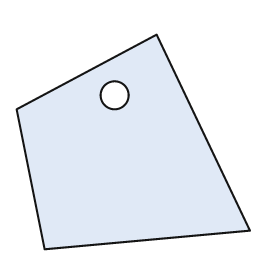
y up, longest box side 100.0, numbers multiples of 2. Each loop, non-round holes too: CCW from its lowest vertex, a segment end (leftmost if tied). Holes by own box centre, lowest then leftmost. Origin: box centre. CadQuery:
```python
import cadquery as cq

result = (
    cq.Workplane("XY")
    .moveTo(-38.0, -46.0)
    .lineTo(50.0, -38.0)
    .lineTo(10.0, 46.0)
    .lineTo(-50.0, 14.0)
    .close()
    .moveTo(-8.0, 20.0)
    .circle(6.0)
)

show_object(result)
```